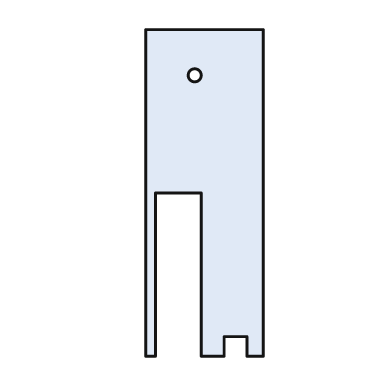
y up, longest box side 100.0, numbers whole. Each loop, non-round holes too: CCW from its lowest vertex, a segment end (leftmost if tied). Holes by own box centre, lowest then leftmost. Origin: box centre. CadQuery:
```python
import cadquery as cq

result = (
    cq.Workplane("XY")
    .moveTo(-18.0, -50.0)
    .lineTo(-15.0, -50.0)
    .lineTo(-15.0, 0.0)
    .lineTo(-1.0, 0.0)
    .lineTo(-1.0, -50.0)
    .lineTo(6.0, -50.0)
    .lineTo(6.0, -44.0)
    .lineTo(13.0, -44.0)
    .lineTo(13.0, -50.0)
    .lineTo(18.0, -50.0)
    .lineTo(18.0, 50.0)
    .lineTo(-18.0, 50.0)
    .close()
    .moveTo(-3.0, 36.0)
    .circle(2.0)
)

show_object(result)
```